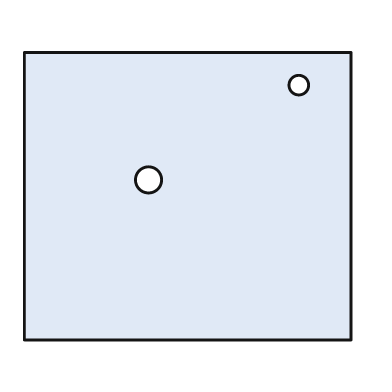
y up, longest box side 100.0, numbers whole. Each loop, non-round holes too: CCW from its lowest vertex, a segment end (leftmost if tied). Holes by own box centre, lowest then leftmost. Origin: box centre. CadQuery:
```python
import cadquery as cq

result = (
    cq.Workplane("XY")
    .moveTo(-50.0, -44.0)
    .lineTo(50.0, -44.0)
    .lineTo(50.0, 44.0)
    .lineTo(-50.0, 44.0)
    .close()
    .moveTo(-12.0, 5.0)
    .circle(4.0)
    .moveTo(34.0, 34.0)
    .circle(3.0)
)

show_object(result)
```